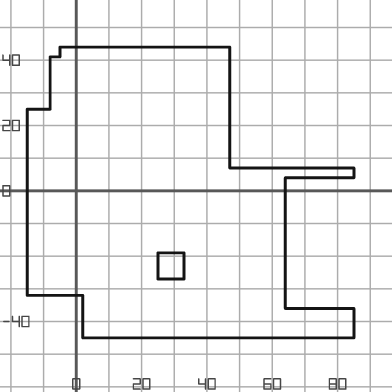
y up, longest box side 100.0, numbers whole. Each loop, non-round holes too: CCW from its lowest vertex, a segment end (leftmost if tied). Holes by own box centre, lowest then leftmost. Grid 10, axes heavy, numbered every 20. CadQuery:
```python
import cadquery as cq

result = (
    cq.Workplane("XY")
    .moveTo(2.0, -45.0)
    .lineTo(85.0, -45.0)
    .lineTo(85.0, -36.0)
    .lineTo(64.0, -36.0)
    .lineTo(64.0, 4.0)
    .lineTo(85.0, 4.0)
    .lineTo(85.0, 7.0)
    .lineTo(47.0, 7.0)
    .lineTo(47.0, 44.0)
    .lineTo(-5.0, 44.0)
    .lineTo(-5.0, 41.0)
    .lineTo(-8.0, 41.0)
    .lineTo(-8.0, 25.0)
    .lineTo(-15.0, 25.0)
    .lineTo(-15.0, -32.0)
    .lineTo(2.0, -32.0)
    .close()
    .moveTo(25.0, -27.0)
    .lineTo(33.0, -27.0)
    .lineTo(33.0, -19.0)
    .lineTo(25.0, -19.0)
    .close()
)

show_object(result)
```